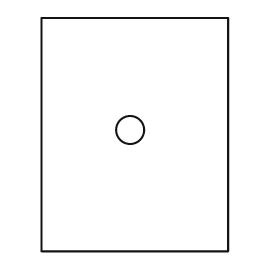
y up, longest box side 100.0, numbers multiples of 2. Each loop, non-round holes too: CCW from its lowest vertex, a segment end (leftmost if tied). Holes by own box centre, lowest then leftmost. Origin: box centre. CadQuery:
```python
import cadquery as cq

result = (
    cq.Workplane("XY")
    .moveTo(-40.0, -50.0)
    .lineTo(40.0, -50.0)
    .lineTo(40.0, 50.0)
    .lineTo(-40.0, 50.0)
    .close()
    .moveTo(-2.0, 2.0)
    .circle(6.0)
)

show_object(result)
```